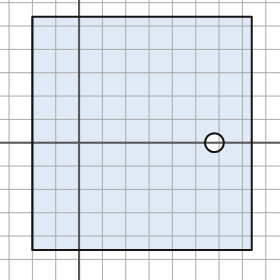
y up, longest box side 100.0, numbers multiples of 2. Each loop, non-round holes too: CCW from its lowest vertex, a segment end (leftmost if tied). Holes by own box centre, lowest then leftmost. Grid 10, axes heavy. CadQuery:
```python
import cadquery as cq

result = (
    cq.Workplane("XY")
    .moveTo(-20.0, -46.0)
    .lineTo(74.0, -46.0)
    .lineTo(74.0, 54.0)
    .lineTo(-20.0, 54.0)
    .close()
    .moveTo(58.0, 0.0)
    .circle(4.0)
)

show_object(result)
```